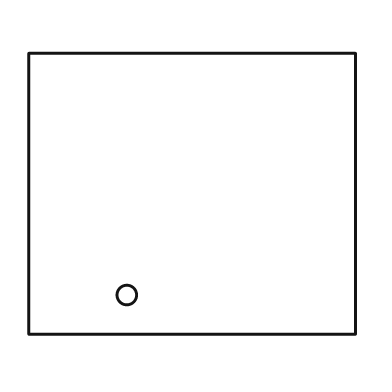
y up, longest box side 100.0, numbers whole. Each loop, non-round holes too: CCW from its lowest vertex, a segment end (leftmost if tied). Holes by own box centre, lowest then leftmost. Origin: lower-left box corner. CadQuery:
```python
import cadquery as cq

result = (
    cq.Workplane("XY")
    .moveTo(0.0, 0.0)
    .lineTo(100.0, 0.0)
    .lineTo(100.0, 86.0)
    .lineTo(0.0, 86.0)
    .close()
    .moveTo(30.0, 12.0)
    .circle(3.0)
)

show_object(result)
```